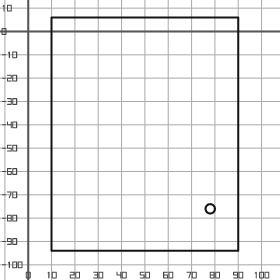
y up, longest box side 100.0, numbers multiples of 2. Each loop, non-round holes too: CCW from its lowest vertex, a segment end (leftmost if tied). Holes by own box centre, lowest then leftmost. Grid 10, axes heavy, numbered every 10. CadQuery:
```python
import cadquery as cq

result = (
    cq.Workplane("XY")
    .moveTo(10.0, -94.0)
    .lineTo(90.0, -94.0)
    .lineTo(90.0, 6.0)
    .lineTo(10.0, 6.0)
    .close()
    .moveTo(78.0, -76.0)
    .circle(2.0)
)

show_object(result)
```